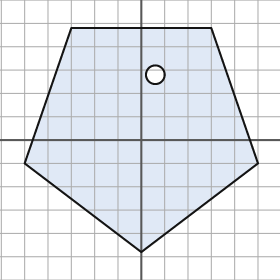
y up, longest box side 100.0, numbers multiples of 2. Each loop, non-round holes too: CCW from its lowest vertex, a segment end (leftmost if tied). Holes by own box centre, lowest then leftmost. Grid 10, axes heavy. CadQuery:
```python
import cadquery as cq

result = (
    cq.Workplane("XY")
    .moveTo(0.0, -48.0)
    .lineTo(50.0, -10.0)
    .lineTo(30.0, 48.0)
    .lineTo(-30.0, 48.0)
    .lineTo(-50.0, -10.0)
    .close()
    .moveTo(6.0, 28.0)
    .circle(4.0)
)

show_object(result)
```